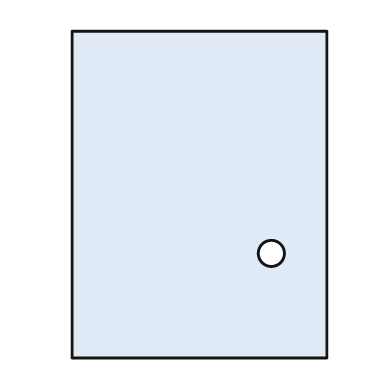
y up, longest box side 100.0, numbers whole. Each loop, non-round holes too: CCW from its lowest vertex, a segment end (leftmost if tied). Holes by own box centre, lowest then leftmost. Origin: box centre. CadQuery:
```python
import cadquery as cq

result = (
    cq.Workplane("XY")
    .moveTo(-39.0, -50.0)
    .lineTo(39.0, -50.0)
    .lineTo(39.0, 50.0)
    .lineTo(-39.0, 50.0)
    .close()
    .moveTo(22.0, -18.0)
    .circle(4.0)
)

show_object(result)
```